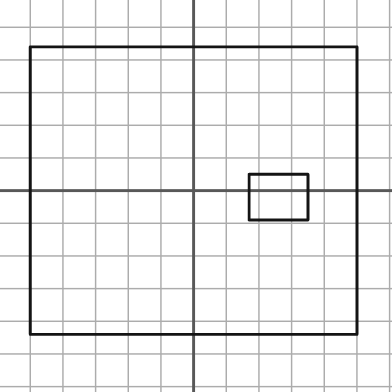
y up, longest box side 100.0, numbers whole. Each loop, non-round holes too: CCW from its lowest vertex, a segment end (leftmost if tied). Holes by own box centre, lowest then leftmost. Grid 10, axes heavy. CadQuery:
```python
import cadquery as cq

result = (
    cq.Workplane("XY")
    .moveTo(-50.0, -44.0)
    .lineTo(50.0, -44.0)
    .lineTo(50.0, 44.0)
    .lineTo(-50.0, 44.0)
    .close()
    .moveTo(17.0, -9.0)
    .lineTo(35.0, -9.0)
    .lineTo(35.0, 5.0)
    .lineTo(17.0, 5.0)
    .close()
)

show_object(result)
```